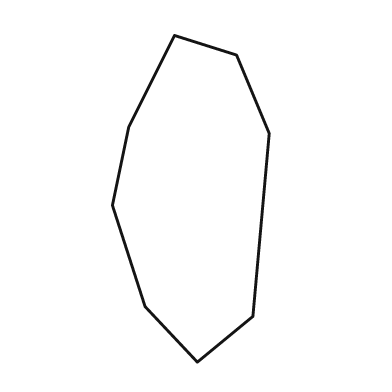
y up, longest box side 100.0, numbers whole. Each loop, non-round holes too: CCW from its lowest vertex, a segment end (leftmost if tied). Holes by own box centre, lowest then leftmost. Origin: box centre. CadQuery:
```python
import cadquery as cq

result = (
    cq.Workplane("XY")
    .moveTo(2.0, -50.0)
    .lineTo(19.0, -36.0)
    .lineTo(24.0, 20.0)
    .lineTo(14.0, 44.0)
    .lineTo(-5.0, 50.0)
    .lineTo(-19.0, 22.0)
    .lineTo(-24.0, -2.0)
    .lineTo(-14.0, -33.0)
    .close()
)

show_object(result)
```